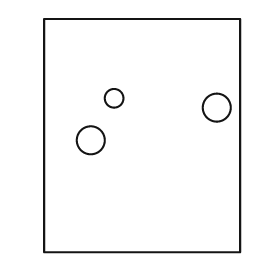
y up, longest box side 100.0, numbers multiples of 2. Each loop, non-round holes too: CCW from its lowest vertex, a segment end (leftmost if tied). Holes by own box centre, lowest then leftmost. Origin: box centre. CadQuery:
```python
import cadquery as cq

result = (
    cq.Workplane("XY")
    .moveTo(-42.0, -50.0)
    .lineTo(42.0, -50.0)
    .lineTo(42.0, 50.0)
    .lineTo(-42.0, 50.0)
    .close()
    .moveTo(-22.0, -2.0)
    .circle(6.0)
    .moveTo(32.0, 12.0)
    .circle(6.0)
    .moveTo(-12.0, 16.0)
    .circle(4.0)
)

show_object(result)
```